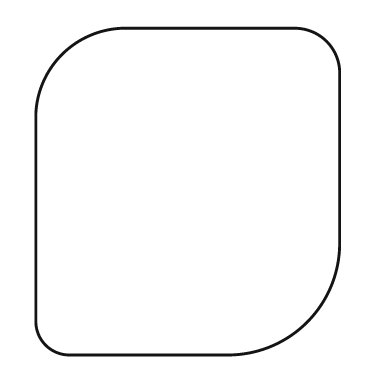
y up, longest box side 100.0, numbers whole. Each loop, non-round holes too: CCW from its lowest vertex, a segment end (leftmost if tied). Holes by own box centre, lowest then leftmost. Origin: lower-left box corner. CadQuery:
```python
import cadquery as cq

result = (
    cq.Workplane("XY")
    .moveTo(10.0, 0.0)
    .lineTo(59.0, 0.0)
    .threePointArc((83.0, 10.0), (93.0, 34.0))
    .lineTo(93.0, 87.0)
    .threePointArc((89.0, 96.0), (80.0, 100.0))
    .lineTo(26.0, 100.0)
    .threePointArc((8.0, 92.0), (0.0, 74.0))
    .lineTo(0.0, 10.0)
    .threePointArc((3.0, 3.0), (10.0, 0.0))
    .close()
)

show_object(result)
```